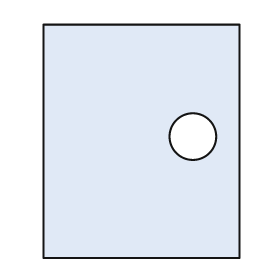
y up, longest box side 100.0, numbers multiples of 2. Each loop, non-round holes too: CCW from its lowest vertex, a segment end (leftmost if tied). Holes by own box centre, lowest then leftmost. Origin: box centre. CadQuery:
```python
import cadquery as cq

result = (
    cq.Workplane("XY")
    .moveTo(-42.0, -50.0)
    .lineTo(42.0, -50.0)
    .lineTo(42.0, 50.0)
    .lineTo(-42.0, 50.0)
    .close()
    .moveTo(22.0, 2.0)
    .circle(10.0)
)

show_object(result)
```